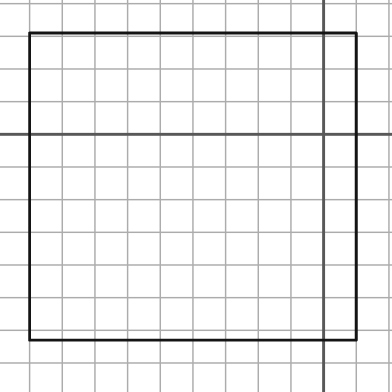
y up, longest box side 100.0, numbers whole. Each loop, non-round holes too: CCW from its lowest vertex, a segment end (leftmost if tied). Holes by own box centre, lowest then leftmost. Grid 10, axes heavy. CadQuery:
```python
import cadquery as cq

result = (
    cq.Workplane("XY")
    .moveTo(-90.0, -63.0)
    .lineTo(10.0, -63.0)
    .lineTo(10.0, 31.0)
    .lineTo(-90.0, 31.0)
    .close()
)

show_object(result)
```